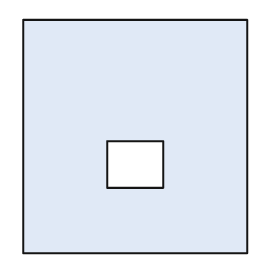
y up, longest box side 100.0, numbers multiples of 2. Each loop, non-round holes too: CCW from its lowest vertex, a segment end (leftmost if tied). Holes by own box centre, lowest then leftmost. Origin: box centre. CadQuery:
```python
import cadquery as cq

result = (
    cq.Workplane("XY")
    .moveTo(-48.0, -50.0)
    .lineTo(48.0, -50.0)
    .lineTo(48.0, 50.0)
    .lineTo(-48.0, 50.0)
    .close()
    .moveTo(-12.0, -22.0)
    .lineTo(12.0, -22.0)
    .lineTo(12.0, -2.0)
    .lineTo(-12.0, -2.0)
    .close()
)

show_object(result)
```